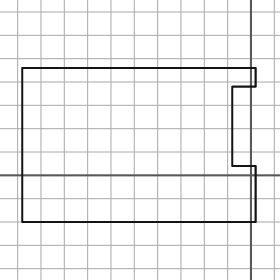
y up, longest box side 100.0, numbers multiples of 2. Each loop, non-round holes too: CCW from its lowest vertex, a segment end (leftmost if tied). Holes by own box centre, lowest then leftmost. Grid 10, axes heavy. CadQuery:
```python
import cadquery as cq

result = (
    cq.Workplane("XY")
    .moveTo(-98.0, -20.0)
    .lineTo(2.0, -20.0)
    .lineTo(2.0, 4.0)
    .lineTo(-8.0, 4.0)
    .lineTo(-8.0, 38.0)
    .lineTo(2.0, 38.0)
    .lineTo(2.0, 46.0)
    .lineTo(-98.0, 46.0)
    .close()
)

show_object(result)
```